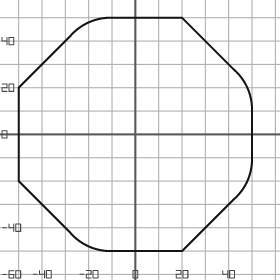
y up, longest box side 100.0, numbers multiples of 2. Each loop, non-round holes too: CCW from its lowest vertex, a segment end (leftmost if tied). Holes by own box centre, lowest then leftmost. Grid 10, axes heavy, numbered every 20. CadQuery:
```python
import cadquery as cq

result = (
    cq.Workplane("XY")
    .moveTo(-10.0, -50.0)
    .lineTo(20.0, -50.0)
    .lineTo(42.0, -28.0)
    .threePointArc((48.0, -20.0), (50.0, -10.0))
    .lineTo(50.0, 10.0)
    .threePointArc((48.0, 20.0), (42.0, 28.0))
    .lineTo(20.0, 50.0)
    .lineTo(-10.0, 50.0)
    .threePointArc((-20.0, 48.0), (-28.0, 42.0))
    .lineTo(-50.0, 20.0)
    .lineTo(-50.0, -20.0)
    .lineTo(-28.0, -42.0)
    .threePointArc((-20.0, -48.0), (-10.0, -50.0))
    .close()
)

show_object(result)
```